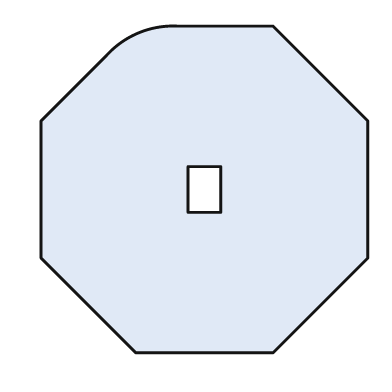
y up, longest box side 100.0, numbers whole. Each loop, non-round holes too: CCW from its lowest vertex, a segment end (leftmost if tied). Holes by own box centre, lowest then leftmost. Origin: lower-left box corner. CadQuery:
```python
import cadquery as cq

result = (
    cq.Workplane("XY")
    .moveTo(29.0, 0.0)
    .lineTo(71.0, 0.0)
    .lineTo(100.0, 29.0)
    .lineTo(100.0, 71.0)
    .lineTo(71.0, 100.0)
    .lineTo(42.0, 100.0)
    .threePointArc((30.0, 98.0), (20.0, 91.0))
    .lineTo(0.0, 71.0)
    .lineTo(0.0, 29.0)
    .close()
    .moveTo(45.0, 43.0)
    .lineTo(55.0, 43.0)
    .lineTo(55.0, 57.0)
    .lineTo(45.0, 57.0)
    .close()
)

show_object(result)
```